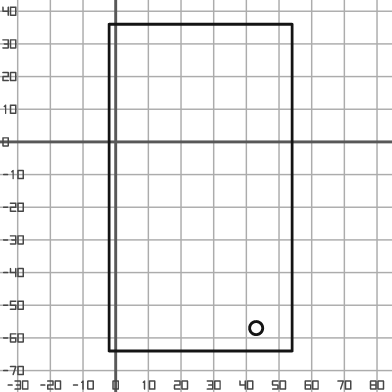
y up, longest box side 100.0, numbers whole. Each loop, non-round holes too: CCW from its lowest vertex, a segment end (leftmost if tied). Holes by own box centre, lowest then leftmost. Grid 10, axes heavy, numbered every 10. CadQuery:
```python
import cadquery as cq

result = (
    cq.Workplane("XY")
    .moveTo(-2.0, -64.0)
    .lineTo(54.0, -64.0)
    .lineTo(54.0, 36.0)
    .lineTo(-2.0, 36.0)
    .close()
    .moveTo(43.0, -57.0)
    .circle(2.0)
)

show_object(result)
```